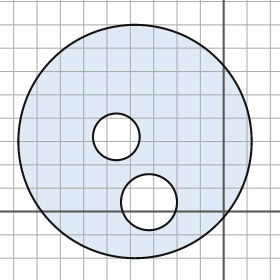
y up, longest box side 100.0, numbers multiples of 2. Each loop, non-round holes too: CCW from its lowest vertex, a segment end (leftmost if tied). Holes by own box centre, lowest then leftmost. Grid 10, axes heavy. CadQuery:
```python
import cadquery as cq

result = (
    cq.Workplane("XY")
    .moveTo(-38.0, 30.0)
    .circle(50.0)
    .moveTo(-32.0, 4.0)
    .circle(12.0)
    .moveTo(-46.0, 32.0)
    .circle(10.0)
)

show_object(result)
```